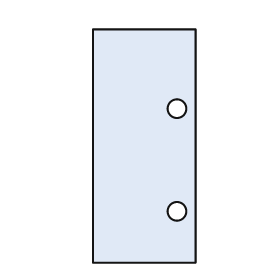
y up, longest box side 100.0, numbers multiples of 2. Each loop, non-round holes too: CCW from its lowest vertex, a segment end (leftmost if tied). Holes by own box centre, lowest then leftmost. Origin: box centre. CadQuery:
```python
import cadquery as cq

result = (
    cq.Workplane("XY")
    .moveTo(-22.0, -50.0)
    .lineTo(22.0, -50.0)
    .lineTo(22.0, 50.0)
    .lineTo(-22.0, 50.0)
    .close()
    .moveTo(14.0, -28.0)
    .circle(4.0)
    .moveTo(14.0, 16.0)
    .circle(4.0)
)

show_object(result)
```